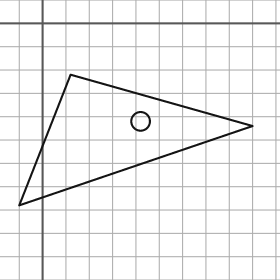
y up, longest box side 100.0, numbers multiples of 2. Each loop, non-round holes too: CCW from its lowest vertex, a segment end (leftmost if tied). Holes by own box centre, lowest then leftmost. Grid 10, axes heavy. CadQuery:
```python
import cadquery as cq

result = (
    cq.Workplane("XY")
    .moveTo(-10.0, -78.0)
    .lineTo(90.0, -44.0)
    .lineTo(12.0, -22.0)
    .close()
    .moveTo(42.0, -42.0)
    .circle(4.0)
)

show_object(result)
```